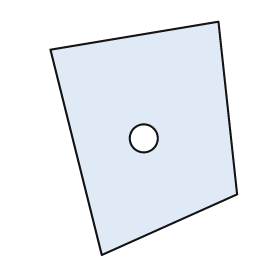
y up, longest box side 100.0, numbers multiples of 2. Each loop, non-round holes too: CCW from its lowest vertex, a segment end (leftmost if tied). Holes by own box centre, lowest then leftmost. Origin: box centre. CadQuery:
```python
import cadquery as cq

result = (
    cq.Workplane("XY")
    .moveTo(-18.0, -50.0)
    .lineTo(40.0, -24.0)
    .lineTo(32.0, 50.0)
    .lineTo(-40.0, 38.0)
    .close()
    .moveTo(0.0, 0.0)
    .circle(6.0)
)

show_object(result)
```